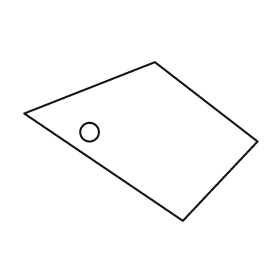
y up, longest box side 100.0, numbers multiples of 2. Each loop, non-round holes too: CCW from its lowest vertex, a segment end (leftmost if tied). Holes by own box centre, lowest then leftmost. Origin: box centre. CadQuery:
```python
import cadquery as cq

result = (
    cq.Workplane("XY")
    .moveTo(18.0, -34.0)
    .lineTo(50.0, 0.0)
    .lineTo(6.0, 34.0)
    .lineTo(-50.0, 12.0)
    .close()
    .moveTo(-22.0, 4.0)
    .circle(4.0)
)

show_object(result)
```